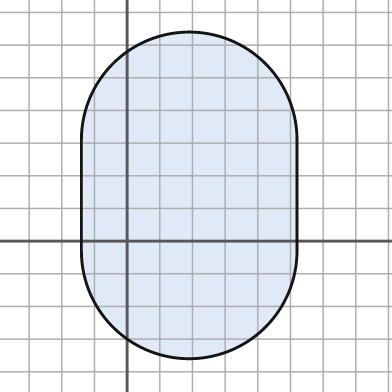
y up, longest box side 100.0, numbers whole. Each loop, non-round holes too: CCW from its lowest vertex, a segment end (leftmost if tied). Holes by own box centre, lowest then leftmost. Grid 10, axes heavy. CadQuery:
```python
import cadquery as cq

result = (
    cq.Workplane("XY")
    .moveTo(-14.0, -3.0)
    .threePointArc((19.0, -36.0), (52.0, -3.0))
    .lineTo(52.0, 31.0)
    .threePointArc((19.0, 64.0), (-14.0, 31.0))
    .close()
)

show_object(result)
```